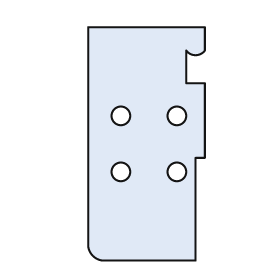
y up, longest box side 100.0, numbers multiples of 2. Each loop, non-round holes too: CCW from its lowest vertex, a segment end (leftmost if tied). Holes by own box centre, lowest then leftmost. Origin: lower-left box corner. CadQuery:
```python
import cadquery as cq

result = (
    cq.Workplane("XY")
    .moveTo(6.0, 0.0)
    .lineTo(46.0, 0.0)
    .lineTo(46.0, 44.0)
    .lineTo(50.0, 44.0)
    .lineTo(50.0, 76.0)
    .lineTo(42.0, 76.0)
    .lineTo(42.0, 90.0)
    .threePointArc((46.0, 88.0), (50.0, 90.0))
    .lineTo(50.0, 100.0)
    .lineTo(0.0, 100.0)
    .lineTo(0.0, 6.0)
    .threePointArc((2.0, 2.0), (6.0, 0.0))
    .close()
    .moveTo(14.0, 38.0)
    .circle(4.0)
    .moveTo(38.0, 38.0)
    .circle(4.0)
    .moveTo(14.0, 62.0)
    .circle(4.0)
    .moveTo(38.0, 62.0)
    .circle(4.0)
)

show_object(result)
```